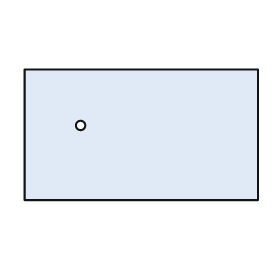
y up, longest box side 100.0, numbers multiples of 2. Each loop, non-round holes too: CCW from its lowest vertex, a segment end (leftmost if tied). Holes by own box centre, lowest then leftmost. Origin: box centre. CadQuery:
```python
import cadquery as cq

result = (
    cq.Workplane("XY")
    .moveTo(-50.0, -28.0)
    .lineTo(50.0, -28.0)
    .lineTo(50.0, 28.0)
    .lineTo(-50.0, 28.0)
    .close()
    .moveTo(-26.0, 4.0)
    .circle(2.0)
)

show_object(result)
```